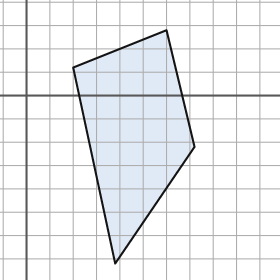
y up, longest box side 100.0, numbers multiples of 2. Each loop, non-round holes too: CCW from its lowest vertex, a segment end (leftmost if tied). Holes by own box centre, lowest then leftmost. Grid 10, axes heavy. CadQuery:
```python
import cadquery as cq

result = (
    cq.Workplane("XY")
    .moveTo(38.0, -72.0)
    .lineTo(72.0, -22.0)
    .lineTo(60.0, 28.0)
    .lineTo(20.0, 12.0)
    .close()
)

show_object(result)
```